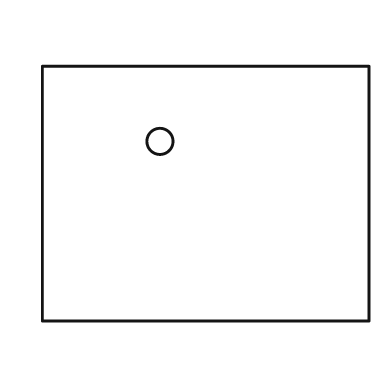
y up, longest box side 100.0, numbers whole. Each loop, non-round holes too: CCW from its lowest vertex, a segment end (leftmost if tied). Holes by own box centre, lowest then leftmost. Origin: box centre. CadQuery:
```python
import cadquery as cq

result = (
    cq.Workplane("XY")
    .moveTo(-50.0, -39.0)
    .lineTo(50.0, -39.0)
    .lineTo(50.0, 39.0)
    .lineTo(-50.0, 39.0)
    .close()
    .moveTo(-14.0, 16.0)
    .circle(4.0)
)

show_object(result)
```